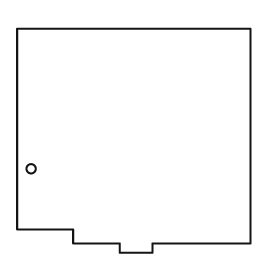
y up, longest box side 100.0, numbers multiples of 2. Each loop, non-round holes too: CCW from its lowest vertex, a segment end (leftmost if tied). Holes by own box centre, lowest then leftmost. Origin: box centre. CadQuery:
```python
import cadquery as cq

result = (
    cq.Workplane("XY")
    .moveTo(-6.0, -48.0)
    .lineTo(8.0, -48.0)
    .lineTo(8.0, -44.0)
    .lineTo(50.0, -44.0)
    .lineTo(50.0, 48.0)
    .lineTo(-50.0, 48.0)
    .lineTo(-50.0, -38.0)
    .lineTo(-26.0, -38.0)
    .lineTo(-26.0, -44.0)
    .lineTo(-6.0, -44.0)
    .close()
    .moveTo(-44.0, -12.0)
    .circle(2.0)
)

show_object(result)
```